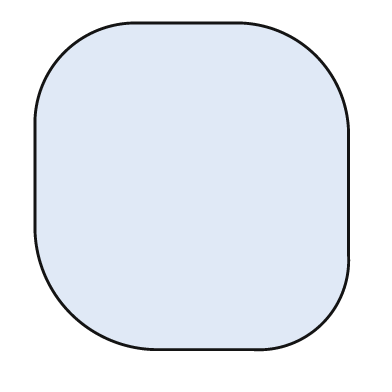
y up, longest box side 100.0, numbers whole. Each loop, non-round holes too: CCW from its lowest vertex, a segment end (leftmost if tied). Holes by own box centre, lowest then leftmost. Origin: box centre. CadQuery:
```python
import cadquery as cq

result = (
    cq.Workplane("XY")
    .moveTo(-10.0, -50.0)
    .lineTo(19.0, -50.0)
    .threePointArc((40.0, -42.0), (48.0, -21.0))
    .lineTo(48.0, 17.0)
    .threePointArc((38.0, 40.0), (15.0, 50.0))
    .lineTo(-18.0, 50.0)
    .threePointArc((-39.0, 41.0), (-48.0, 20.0))
    .lineTo(-48.0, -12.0)
    .threePointArc((-37.0, -39.0), (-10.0, -50.0))
    .close()
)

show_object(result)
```